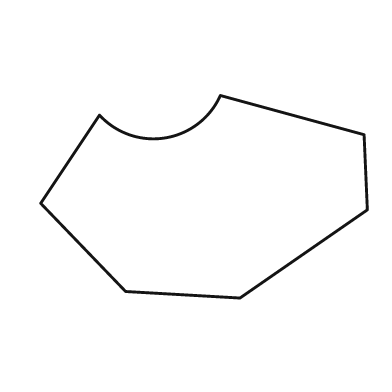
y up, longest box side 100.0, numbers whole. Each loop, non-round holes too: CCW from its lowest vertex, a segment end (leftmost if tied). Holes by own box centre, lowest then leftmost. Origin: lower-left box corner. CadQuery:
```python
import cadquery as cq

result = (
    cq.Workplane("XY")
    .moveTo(61.0, 0.0)
    .lineTo(100.0, 27.0)
    .lineTo(99.0, 50.0)
    .lineTo(55.0, 62.0)
    .threePointArc((38.0, 49.0), (18.0, 56.0))
    .lineTo(0.0, 29.0)
    .lineTo(26.0, 2.0)
    .close()
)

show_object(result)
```